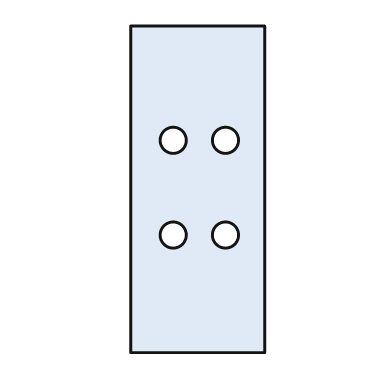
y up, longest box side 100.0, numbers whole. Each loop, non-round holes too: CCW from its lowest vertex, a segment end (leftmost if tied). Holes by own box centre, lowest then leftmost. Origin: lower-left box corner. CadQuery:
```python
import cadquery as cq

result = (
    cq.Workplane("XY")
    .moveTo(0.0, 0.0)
    .lineTo(41.0, 0.0)
    .lineTo(41.0, 100.0)
    .lineTo(0.0, 100.0)
    .close()
    .moveTo(13.0, 36.0)
    .circle(4.0)
    .moveTo(29.0, 36.0)
    .circle(4.0)
    .moveTo(13.0, 65.0)
    .circle(4.0)
    .moveTo(29.0, 65.0)
    .circle(4.0)
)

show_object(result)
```